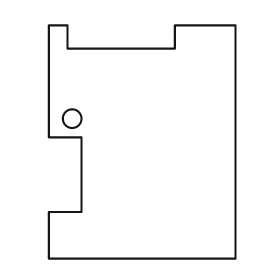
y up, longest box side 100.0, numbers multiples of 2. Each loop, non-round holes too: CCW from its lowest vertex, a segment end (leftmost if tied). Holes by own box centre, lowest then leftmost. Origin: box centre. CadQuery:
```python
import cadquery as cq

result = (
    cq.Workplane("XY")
    .moveTo(-40.0, -50.0)
    .lineTo(40.0, -50.0)
    .lineTo(40.0, 50.0)
    .lineTo(14.0, 50.0)
    .lineTo(14.0, 40.0)
    .lineTo(-32.0, 40.0)
    .lineTo(-32.0, 50.0)
    .lineTo(-40.0, 50.0)
    .lineTo(-40.0, 2.0)
    .lineTo(-26.0, 2.0)
    .lineTo(-26.0, -30.0)
    .lineTo(-40.0, -30.0)
    .close()
    .moveTo(-30.0, 10.0)
    .circle(4.0)
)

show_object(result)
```